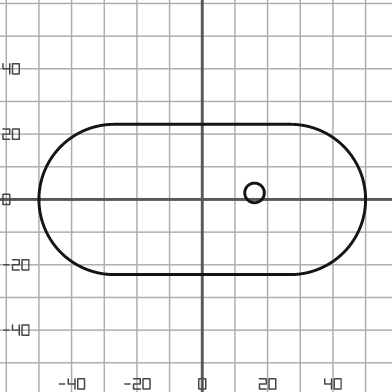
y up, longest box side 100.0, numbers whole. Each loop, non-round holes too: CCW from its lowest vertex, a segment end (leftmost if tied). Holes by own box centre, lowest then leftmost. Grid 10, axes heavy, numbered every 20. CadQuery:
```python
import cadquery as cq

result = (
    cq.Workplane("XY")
    .moveTo(-27.0, -23.0)
    .lineTo(27.0, -23.0)
    .threePointArc((50.0, 0.0), (27.0, 23.0))
    .lineTo(-27.0, 23.0)
    .threePointArc((-50.0, 0.0), (-27.0, -23.0))
    .close()
    .moveTo(16.0, 2.0)
    .circle(3.0)
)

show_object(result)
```